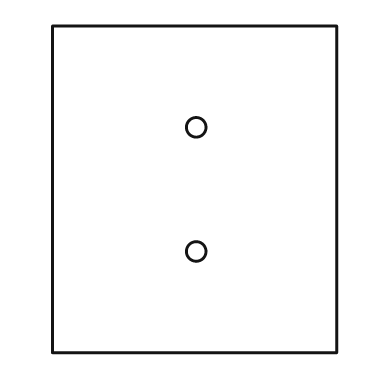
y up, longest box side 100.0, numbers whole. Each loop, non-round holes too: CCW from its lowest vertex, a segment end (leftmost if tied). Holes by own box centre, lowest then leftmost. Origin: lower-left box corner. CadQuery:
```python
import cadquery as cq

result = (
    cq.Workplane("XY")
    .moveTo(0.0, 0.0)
    .lineTo(87.0, 0.0)
    .lineTo(87.0, 100.0)
    .lineTo(0.0, 100.0)
    .close()
    .moveTo(44.0, 31.0)
    .circle(3.0)
    .moveTo(44.0, 69.0)
    .circle(3.0)
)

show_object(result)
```